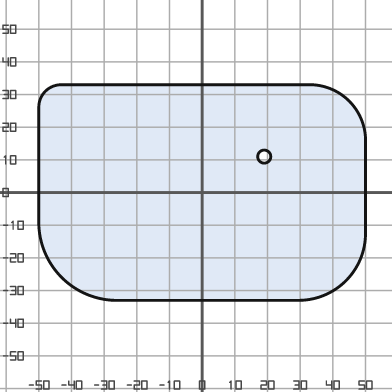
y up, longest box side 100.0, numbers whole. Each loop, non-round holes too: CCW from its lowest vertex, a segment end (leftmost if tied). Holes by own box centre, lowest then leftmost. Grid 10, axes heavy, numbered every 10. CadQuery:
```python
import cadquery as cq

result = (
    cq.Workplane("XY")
    .moveTo(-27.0, -33.0)
    .lineTo(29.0, -33.0)
    .threePointArc((44.0, -27.0), (50.0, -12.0))
    .lineTo(50.0, 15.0)
    .threePointArc((45.0, 28.0), (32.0, 33.0))
    .lineTo(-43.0, 33.0)
    .threePointArc((-48.0, 31.0), (-50.0, 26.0))
    .lineTo(-50.0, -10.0)
    .threePointArc((-43.0, -26.0), (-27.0, -33.0))
    .close()
    .moveTo(19.0, 11.0)
    .circle(2.0)
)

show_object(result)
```